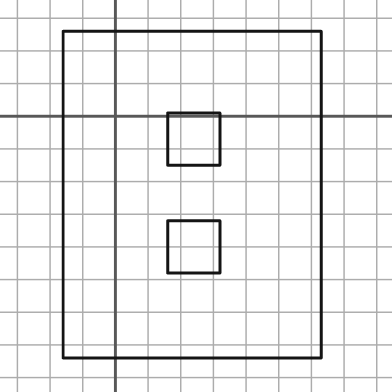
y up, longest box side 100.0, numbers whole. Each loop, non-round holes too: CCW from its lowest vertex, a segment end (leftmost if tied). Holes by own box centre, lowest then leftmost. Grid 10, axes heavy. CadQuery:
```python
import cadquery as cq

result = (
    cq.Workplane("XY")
    .moveTo(-16.0, -74.0)
    .lineTo(63.0, -74.0)
    .lineTo(63.0, 26.0)
    .lineTo(-16.0, 26.0)
    .close()
    .moveTo(16.0, -48.0)
    .lineTo(32.0, -48.0)
    .lineTo(32.0, -32.0)
    .lineTo(16.0, -32.0)
    .close()
    .moveTo(16.0, -15.0)
    .lineTo(32.0, -15.0)
    .lineTo(32.0, 1.0)
    .lineTo(16.0, 1.0)
    .close()
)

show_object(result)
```